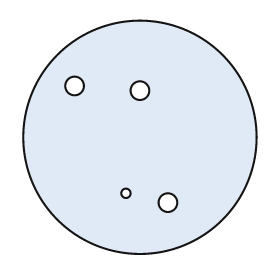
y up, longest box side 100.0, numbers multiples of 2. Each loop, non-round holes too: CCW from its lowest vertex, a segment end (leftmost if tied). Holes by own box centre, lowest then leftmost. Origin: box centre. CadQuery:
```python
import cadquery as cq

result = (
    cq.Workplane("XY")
    .moveTo(0.0, 0.0)
    .circle(50.0)
    .moveTo(12.0, -28.0)
    .circle(4.0)
    .moveTo(-6.0, -24.0)
    .circle(2.0)
    .moveTo(0.0, 20.0)
    .circle(4.0)
    .moveTo(-28.0, 22.0)
    .circle(4.0)
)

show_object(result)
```